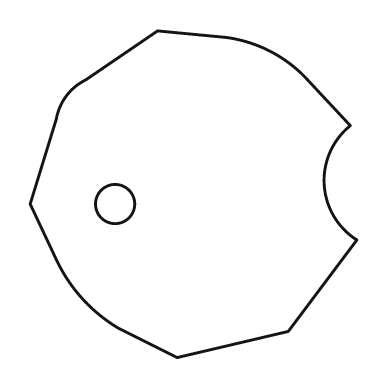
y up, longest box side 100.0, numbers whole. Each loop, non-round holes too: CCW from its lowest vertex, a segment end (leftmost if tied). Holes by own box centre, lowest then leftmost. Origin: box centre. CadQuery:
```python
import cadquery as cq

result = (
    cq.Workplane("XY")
    .moveTo(-5.0, -50.0)
    .lineTo(29.0, -42.0)
    .lineTo(50.0, -14.0)
    .threePointArc((40.0, 3.0), (48.0, 21.0))
    .lineTo(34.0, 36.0)
    .threePointArc((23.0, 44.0), (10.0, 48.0))
    .lineTo(-11.0, 50.0)
    .lineTo(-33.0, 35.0)
    .threePointArc((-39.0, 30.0), (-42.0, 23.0))
    .lineTo(-50.0, -3.0)
    .lineTo(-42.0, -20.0)
    .threePointArc((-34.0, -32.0), (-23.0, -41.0))
    .close()
    .moveTo(-24.0, -3.0)
    .circle(6.0)
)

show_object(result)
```